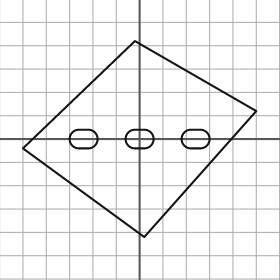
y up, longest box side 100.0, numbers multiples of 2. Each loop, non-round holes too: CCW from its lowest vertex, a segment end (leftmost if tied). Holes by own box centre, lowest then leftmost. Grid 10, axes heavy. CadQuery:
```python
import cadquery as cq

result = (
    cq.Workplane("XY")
    .moveTo(2.0, -42.0)
    .lineTo(50.0, 12.0)
    .lineTo(-2.0, 42.0)
    .lineTo(-50.0, -4.0)
    .close()
    .moveTo(-26.0, -4.0)
    .lineTo(-22.0, -4.0)
    .threePointArc((-18.0, 0.0), (-22.0, 4.0))
    .lineTo(-26.0, 4.0)
    .threePointArc((-30.0, 0.0), (-26.0, -4.0))
    .close()
    .moveTo(-2.0, -4.0)
    .lineTo(2.0, -4.0)
    .threePointArc((6.0, 0.0), (2.0, 4.0))
    .lineTo(-2.0, 4.0)
    .threePointArc((-6.0, 0.0), (-2.0, -4.0))
    .close()
    .moveTo(22.0, -4.0)
    .lineTo(26.0, -4.0)
    .threePointArc((30.0, 0.0), (26.0, 4.0))
    .lineTo(22.0, 4.0)
    .threePointArc((18.0, 0.0), (22.0, -4.0))
    .close()
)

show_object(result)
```